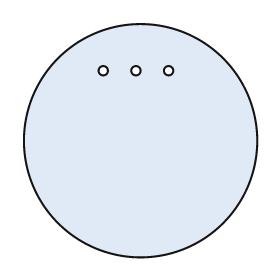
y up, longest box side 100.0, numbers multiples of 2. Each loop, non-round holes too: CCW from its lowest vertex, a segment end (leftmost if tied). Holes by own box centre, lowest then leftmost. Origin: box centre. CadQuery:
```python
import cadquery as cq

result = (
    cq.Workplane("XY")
    .moveTo(0.0, 0.0)
    .circle(50.0)
    .moveTo(-16.0, 30.0)
    .circle(2.0)
    .moveTo(-2.0, 30.0)
    .circle(2.0)
    .moveTo(12.0, 30.0)
    .circle(2.0)
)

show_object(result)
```